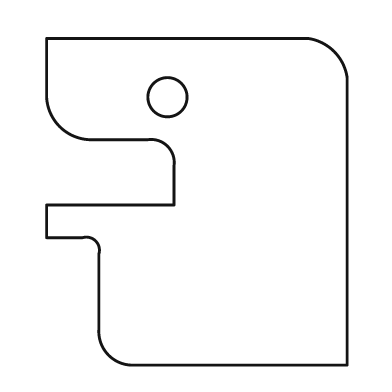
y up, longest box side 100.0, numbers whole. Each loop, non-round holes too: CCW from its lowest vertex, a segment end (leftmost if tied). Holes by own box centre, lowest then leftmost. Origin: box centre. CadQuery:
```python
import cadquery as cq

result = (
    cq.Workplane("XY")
    .moveTo(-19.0, -50.0)
    .lineTo(46.0, -50.0)
    .lineTo(46.0, 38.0)
    .threePointArc((42.0, 46.0), (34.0, 50.0))
    .lineTo(-46.0, 50.0)
    .lineTo(-46.0, 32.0)
    .threePointArc((-42.0, 23.0), (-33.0, 19.0))
    .lineTo(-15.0, 19.0)
    .threePointArc((-9.0, 17.0), (-7.0, 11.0))
    .lineTo(-7.0, -1.0)
    .lineTo(-46.0, -1.0)
    .lineTo(-46.0, -11.0)
    .lineTo(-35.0, -11.0)
    .threePointArc((-31.0, -12.0), (-30.0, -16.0))
    .lineTo(-30.0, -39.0)
    .threePointArc((-27.0, -47.0), (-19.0, -50.0))
    .close()
    .moveTo(-9.0, 32.0)
    .circle(6.0)
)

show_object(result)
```